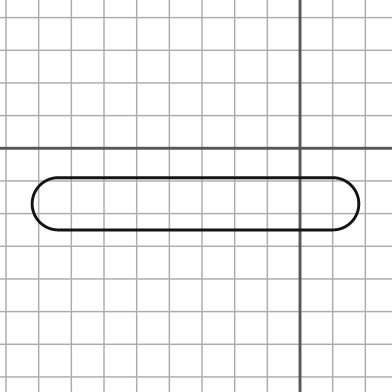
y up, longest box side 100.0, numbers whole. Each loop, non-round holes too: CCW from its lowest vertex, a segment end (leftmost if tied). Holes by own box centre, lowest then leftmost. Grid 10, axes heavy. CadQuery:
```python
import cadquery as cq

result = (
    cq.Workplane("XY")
    .moveTo(-74.0, -25.0)
    .lineTo(10.0, -25.0)
    .threePointArc((18.0, -17.0), (10.0, -9.0))
    .lineTo(-74.0, -9.0)
    .threePointArc((-82.0, -17.0), (-74.0, -25.0))
    .close()
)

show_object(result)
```